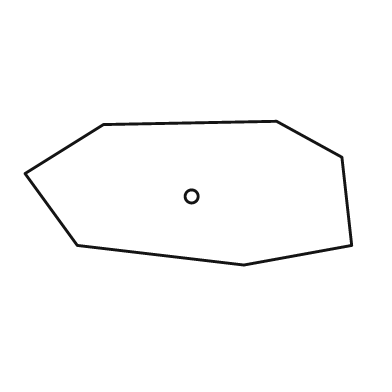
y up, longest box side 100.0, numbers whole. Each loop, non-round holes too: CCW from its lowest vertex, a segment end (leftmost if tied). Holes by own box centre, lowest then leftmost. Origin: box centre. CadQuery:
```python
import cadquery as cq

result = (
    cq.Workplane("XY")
    .moveTo(17.0, -22.0)
    .lineTo(50.0, -16.0)
    .lineTo(47.0, 11.0)
    .lineTo(27.0, 22.0)
    .lineTo(-26.0, 21.0)
    .lineTo(-50.0, 6.0)
    .lineTo(-34.0, -16.0)
    .close()
    .moveTo(1.0, -1.0)
    .circle(2.0)
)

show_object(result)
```